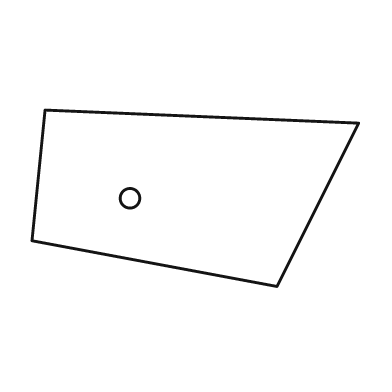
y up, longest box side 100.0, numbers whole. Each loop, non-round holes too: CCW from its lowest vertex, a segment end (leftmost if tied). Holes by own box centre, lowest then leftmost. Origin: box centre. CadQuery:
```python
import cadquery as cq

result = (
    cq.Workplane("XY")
    .moveTo(25.0, -27.0)
    .lineTo(50.0, 23.0)
    .lineTo(-46.0, 27.0)
    .lineTo(-50.0, -13.0)
    .close()
    .moveTo(-20.0, 0.0)
    .circle(3.0)
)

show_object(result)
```